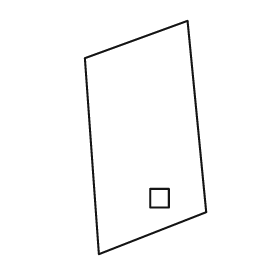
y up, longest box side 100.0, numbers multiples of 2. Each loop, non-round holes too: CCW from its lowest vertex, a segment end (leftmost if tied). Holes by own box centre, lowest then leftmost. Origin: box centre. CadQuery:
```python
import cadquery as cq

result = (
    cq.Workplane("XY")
    .moveTo(-20.0, -50.0)
    .lineTo(26.0, -32.0)
    .lineTo(18.0, 50.0)
    .lineTo(-26.0, 34.0)
    .close()
    .moveTo(2.0, -30.0)
    .lineTo(10.0, -30.0)
    .lineTo(10.0, -22.0)
    .lineTo(2.0, -22.0)
    .close()
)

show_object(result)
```